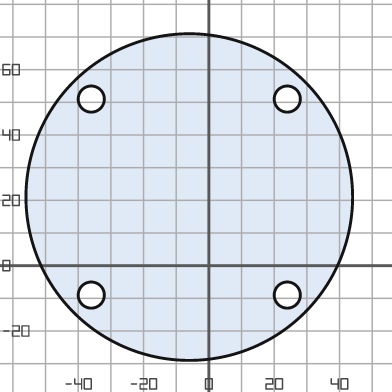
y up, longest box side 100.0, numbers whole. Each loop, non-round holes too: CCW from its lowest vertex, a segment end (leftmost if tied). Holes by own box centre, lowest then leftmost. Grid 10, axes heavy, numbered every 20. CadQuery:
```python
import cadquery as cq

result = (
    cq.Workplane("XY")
    .moveTo(-6.0, 21.0)
    .circle(50.0)
    .moveTo(-36.0, -9.0)
    .circle(4.0)
    .moveTo(24.0, -9.0)
    .circle(4.0)
    .moveTo(-36.0, 51.0)
    .circle(4.0)
    .moveTo(24.0, 51.0)
    .circle(4.0)
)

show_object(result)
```